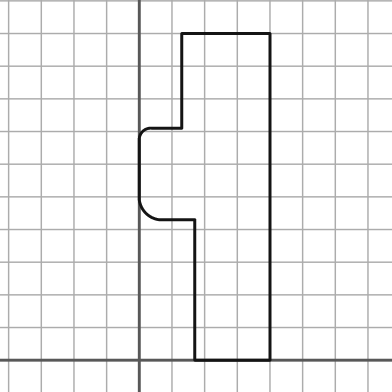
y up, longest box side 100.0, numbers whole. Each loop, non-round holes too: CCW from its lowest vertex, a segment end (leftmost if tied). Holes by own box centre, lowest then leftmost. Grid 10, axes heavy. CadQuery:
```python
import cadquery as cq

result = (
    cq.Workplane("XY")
    .moveTo(17.0, 0.0)
    .lineTo(40.0, 0.0)
    .lineTo(40.0, 100.0)
    .lineTo(13.0, 100.0)
    .lineTo(13.0, 71.0)
    .lineTo(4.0, 71.0)
    .threePointArc((1.0, 70.0), (0.0, 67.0))
    .lineTo(0.0, 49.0)
    .threePointArc((2.0, 45.0), (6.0, 43.0))
    .lineTo(17.0, 43.0)
    .close()
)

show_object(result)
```